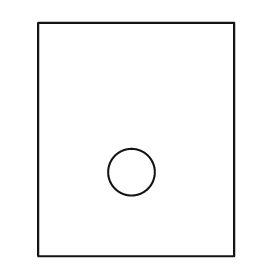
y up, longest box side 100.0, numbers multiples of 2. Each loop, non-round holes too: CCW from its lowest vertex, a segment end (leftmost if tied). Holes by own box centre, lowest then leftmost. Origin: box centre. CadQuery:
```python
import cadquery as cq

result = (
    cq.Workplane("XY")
    .moveTo(-42.0, -50.0)
    .lineTo(42.0, -50.0)
    .lineTo(42.0, 50.0)
    .lineTo(-42.0, 50.0)
    .close()
    .moveTo(-2.0, -14.0)
    .circle(10.0)
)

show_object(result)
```